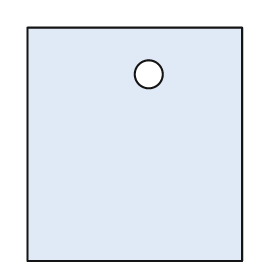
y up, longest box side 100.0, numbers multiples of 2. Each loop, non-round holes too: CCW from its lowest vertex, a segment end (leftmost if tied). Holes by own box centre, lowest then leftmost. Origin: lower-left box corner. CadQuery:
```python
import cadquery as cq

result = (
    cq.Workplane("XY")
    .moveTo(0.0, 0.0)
    .lineTo(92.0, 0.0)
    .lineTo(92.0, 100.0)
    .lineTo(0.0, 100.0)
    .close()
    .moveTo(52.0, 80.0)
    .circle(6.0)
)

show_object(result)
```